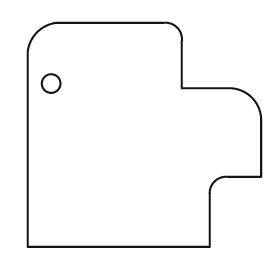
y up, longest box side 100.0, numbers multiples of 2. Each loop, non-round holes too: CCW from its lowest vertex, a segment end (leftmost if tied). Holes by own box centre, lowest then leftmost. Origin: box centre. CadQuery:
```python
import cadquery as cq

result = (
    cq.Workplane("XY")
    .moveTo(-50.0, -48.0)
    .lineTo(28.0, -48.0)
    .lineTo(28.0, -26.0)
    .threePointArc((30.0, -20.0), (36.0, -18.0))
    .lineTo(50.0, -18.0)
    .lineTo(50.0, 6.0)
    .threePointArc((46.0, 16.0), (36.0, 20.0))
    .lineTo(16.0, 20.0)
    .lineTo(16.0, 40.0)
    .threePointArc((14.0, 46.0), (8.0, 48.0))
    .lineTo(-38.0, 48.0)
    .threePointArc((-46.0, 44.0), (-50.0, 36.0))
    .close()
    .moveTo(-40.0, 22.0)
    .circle(4.0)
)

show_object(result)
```